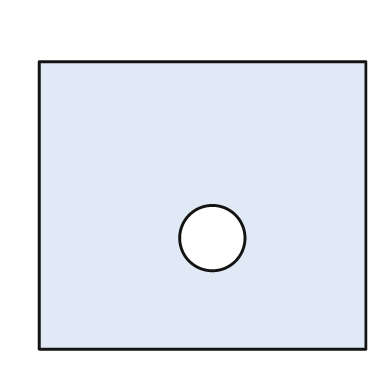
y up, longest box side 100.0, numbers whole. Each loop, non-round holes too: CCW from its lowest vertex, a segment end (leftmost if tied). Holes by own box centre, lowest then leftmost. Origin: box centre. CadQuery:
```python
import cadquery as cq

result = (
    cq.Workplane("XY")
    .moveTo(-50.0, -44.0)
    .lineTo(50.0, -44.0)
    .lineTo(50.0, 44.0)
    .lineTo(-50.0, 44.0)
    .close()
    .moveTo(3.0, -10.0)
    .circle(10.0)
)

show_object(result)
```